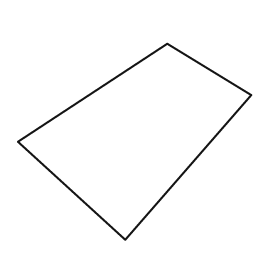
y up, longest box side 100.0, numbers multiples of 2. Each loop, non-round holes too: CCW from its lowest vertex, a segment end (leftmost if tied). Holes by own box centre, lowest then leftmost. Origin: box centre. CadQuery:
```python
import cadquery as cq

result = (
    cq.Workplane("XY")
    .moveTo(-4.0, -42.0)
    .lineTo(50.0, 20.0)
    .lineTo(14.0, 42.0)
    .lineTo(-50.0, 0.0)
    .close()
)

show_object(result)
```